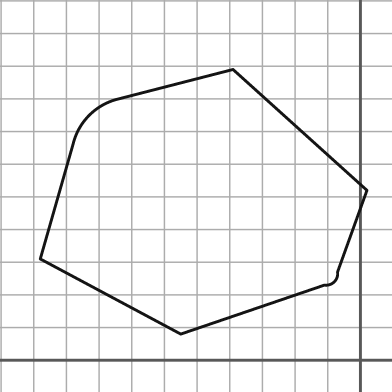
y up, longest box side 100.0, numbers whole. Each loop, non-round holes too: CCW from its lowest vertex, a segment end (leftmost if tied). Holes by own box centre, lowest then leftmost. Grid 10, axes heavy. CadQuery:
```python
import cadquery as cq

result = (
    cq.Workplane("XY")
    .moveTo(-55.0, 8.0)
    .lineTo(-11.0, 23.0)
    .threePointArc((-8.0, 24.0), (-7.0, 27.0))
    .lineTo(2.0, 52.0)
    .lineTo(-39.0, 89.0)
    .lineTo(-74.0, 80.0)
    .threePointArc((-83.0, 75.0), (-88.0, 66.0))
    .lineTo(-98.0, 31.0)
    .close()
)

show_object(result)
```